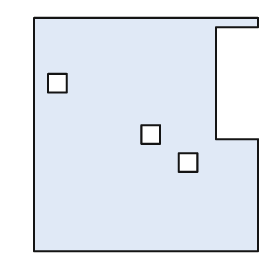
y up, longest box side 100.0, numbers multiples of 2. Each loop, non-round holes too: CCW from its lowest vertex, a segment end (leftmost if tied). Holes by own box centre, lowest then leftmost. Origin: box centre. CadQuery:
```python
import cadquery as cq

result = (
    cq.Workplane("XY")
    .moveTo(-48.0, -50.0)
    .lineTo(48.0, -50.0)
    .lineTo(48.0, -2.0)
    .lineTo(30.0, -2.0)
    .lineTo(30.0, 46.0)
    .lineTo(48.0, 46.0)
    .lineTo(48.0, 50.0)
    .lineTo(-48.0, 50.0)
    .close()
    .moveTo(14.0, -16.0)
    .lineTo(22.0, -16.0)
    .lineTo(22.0, -8.0)
    .lineTo(14.0, -8.0)
    .close()
    .moveTo(-2.0, -4.0)
    .lineTo(6.0, -4.0)
    .lineTo(6.0, 4.0)
    .lineTo(-2.0, 4.0)
    .close()
    .moveTo(-42.0, 18.0)
    .lineTo(-34.0, 18.0)
    .lineTo(-34.0, 26.0)
    .lineTo(-42.0, 26.0)
    .close()
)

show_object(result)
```